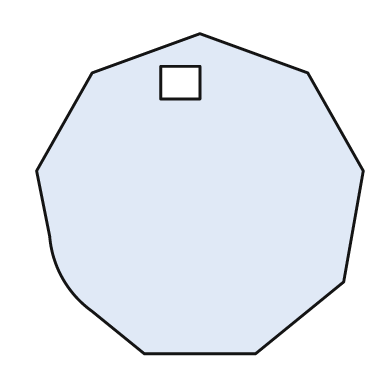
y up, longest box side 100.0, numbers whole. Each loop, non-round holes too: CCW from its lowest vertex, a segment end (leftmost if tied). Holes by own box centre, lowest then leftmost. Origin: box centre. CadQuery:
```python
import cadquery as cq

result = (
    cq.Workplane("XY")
    .moveTo(-17.0, -49.0)
    .lineTo(17.0, -49.0)
    .lineTo(44.0, -27.0)
    .lineTo(50.0, 7.0)
    .lineTo(33.0, 37.0)
    .lineTo(0.0, 49.0)
    .lineTo(-33.0, 37.0)
    .lineTo(-50.0, 7.0)
    .lineTo(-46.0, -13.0)
    .threePointArc((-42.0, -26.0), (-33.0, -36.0))
    .close()
    .moveTo(-12.0, 29.0)
    .lineTo(0.0, 29.0)
    .lineTo(0.0, 39.0)
    .lineTo(-12.0, 39.0)
    .close()
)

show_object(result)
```